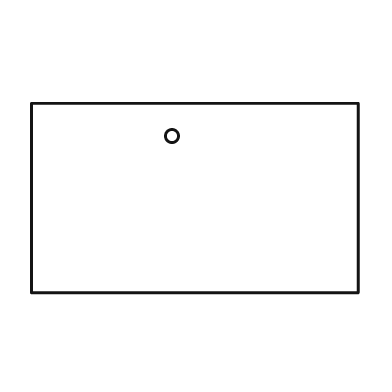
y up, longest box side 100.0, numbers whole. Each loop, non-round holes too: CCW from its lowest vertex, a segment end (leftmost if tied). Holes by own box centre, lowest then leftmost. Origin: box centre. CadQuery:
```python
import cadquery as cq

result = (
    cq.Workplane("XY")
    .moveTo(-50.0, -29.0)
    .lineTo(50.0, -29.0)
    .lineTo(50.0, 29.0)
    .lineTo(-50.0, 29.0)
    .close()
    .moveTo(-7.0, 19.0)
    .circle(2.0)
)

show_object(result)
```